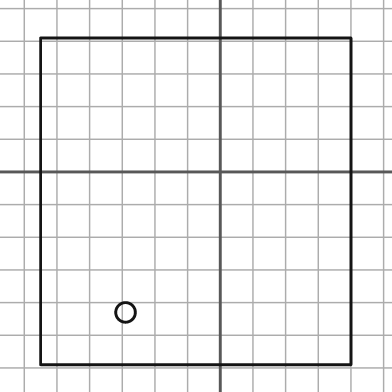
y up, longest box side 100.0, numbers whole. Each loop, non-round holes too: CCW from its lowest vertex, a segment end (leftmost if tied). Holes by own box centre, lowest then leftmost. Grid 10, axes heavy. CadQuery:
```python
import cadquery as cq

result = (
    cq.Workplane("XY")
    .moveTo(-55.0, -59.0)
    .lineTo(40.0, -59.0)
    .lineTo(40.0, 41.0)
    .lineTo(-55.0, 41.0)
    .close()
    .moveTo(-29.0, -43.0)
    .circle(3.0)
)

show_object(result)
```